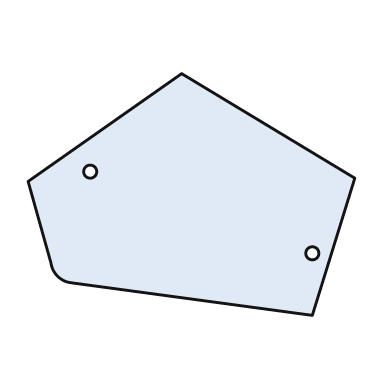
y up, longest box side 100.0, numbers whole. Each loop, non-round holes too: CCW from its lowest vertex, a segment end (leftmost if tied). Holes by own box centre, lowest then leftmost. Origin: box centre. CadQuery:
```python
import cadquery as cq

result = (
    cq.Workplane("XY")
    .moveTo(37.0, -37.0)
    .lineTo(50.0, 5.0)
    .lineTo(-3.0, 37.0)
    .lineTo(-50.0, 4.0)
    .lineTo(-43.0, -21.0)
    .threePointArc((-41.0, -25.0), (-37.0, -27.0))
    .close()
    .moveTo(37.0, -18.0)
    .circle(2.0)
    .moveTo(-31.0, 7.0)
    .circle(2.0)
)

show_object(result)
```